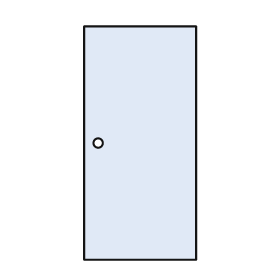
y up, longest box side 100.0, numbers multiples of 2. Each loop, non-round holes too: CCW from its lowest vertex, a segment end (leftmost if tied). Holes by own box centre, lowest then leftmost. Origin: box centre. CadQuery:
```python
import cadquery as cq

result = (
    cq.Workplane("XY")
    .moveTo(-24.0, -50.0)
    .lineTo(24.0, -50.0)
    .lineTo(24.0, 50.0)
    .lineTo(-24.0, 50.0)
    .close()
    .moveTo(-18.0, 0.0)
    .circle(2.0)
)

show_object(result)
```